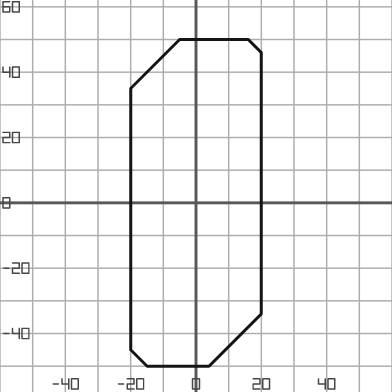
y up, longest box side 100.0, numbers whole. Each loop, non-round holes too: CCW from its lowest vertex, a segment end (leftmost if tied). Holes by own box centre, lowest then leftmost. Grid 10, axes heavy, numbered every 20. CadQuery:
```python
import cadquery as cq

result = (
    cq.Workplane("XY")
    .moveTo(-15.0, -50.0)
    .lineTo(4.0, -50.0)
    .lineTo(20.0, -34.0)
    .lineTo(20.0, 46.0)
    .lineTo(16.0, 50.0)
    .lineTo(-5.0, 50.0)
    .lineTo(-20.0, 35.0)
    .lineTo(-20.0, -45.0)
    .close()
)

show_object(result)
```